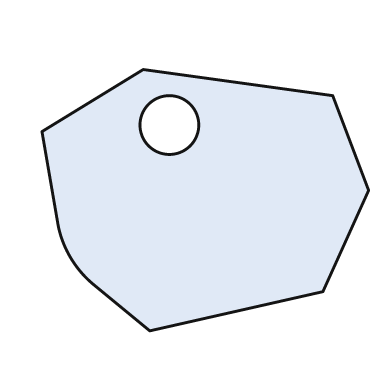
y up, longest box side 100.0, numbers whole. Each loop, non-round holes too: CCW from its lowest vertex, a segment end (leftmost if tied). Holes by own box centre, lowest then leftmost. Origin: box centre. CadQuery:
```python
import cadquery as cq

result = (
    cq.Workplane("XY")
    .moveTo(-17.0, -40.0)
    .lineTo(36.0, -28.0)
    .lineTo(50.0, 3.0)
    .lineTo(39.0, 32.0)
    .lineTo(-19.0, 40.0)
    .lineTo(-50.0, 21.0)
    .lineTo(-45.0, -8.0)
    .threePointArc((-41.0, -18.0), (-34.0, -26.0))
    .close()
    .moveTo(-11.0, 23.0)
    .circle(9.0)
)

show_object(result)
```